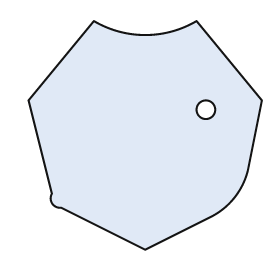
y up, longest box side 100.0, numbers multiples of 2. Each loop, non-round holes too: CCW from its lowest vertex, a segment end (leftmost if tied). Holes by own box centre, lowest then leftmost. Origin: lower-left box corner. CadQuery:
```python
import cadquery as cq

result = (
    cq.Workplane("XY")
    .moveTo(50.0, 0.0)
    .lineTo(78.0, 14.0)
    .threePointArc((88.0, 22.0), (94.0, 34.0))
    .lineTo(100.0, 64.0)
    .lineTo(72.0, 98.0)
    .threePointArc((50.0, 92.0), (28.0, 98.0))
    .lineTo(0.0, 64.0)
    .lineTo(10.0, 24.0)
    .threePointArc((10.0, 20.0), (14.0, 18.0))
    .close()
    .moveTo(76.0, 60.0)
    .circle(4.0)
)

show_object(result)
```